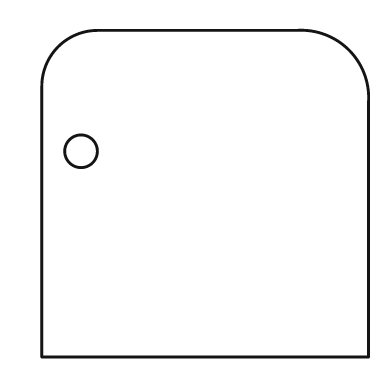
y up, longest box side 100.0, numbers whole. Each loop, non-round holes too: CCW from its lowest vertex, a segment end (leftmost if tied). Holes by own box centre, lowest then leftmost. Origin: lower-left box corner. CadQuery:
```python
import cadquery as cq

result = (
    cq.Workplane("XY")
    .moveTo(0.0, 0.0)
    .lineTo(100.0, 0.0)
    .lineTo(100.0, 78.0)
    .threePointArc((94.0, 94.0), (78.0, 100.0))
    .lineTo(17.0, 100.0)
    .threePointArc((5.0, 95.0), (0.0, 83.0))
    .close()
    .moveTo(12.0, 63.0)
    .circle(5.0)
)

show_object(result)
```